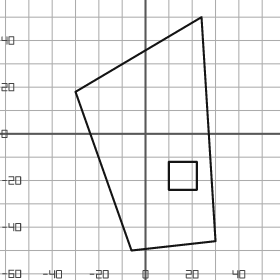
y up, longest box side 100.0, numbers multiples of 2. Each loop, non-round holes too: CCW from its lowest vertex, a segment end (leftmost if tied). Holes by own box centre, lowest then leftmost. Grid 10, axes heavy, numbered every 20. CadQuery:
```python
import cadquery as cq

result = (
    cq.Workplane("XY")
    .moveTo(-6.0, -50.0)
    .lineTo(30.0, -46.0)
    .lineTo(24.0, 50.0)
    .lineTo(-30.0, 18.0)
    .close()
    .moveTo(10.0, -24.0)
    .lineTo(22.0, -24.0)
    .lineTo(22.0, -12.0)
    .lineTo(10.0, -12.0)
    .close()
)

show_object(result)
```